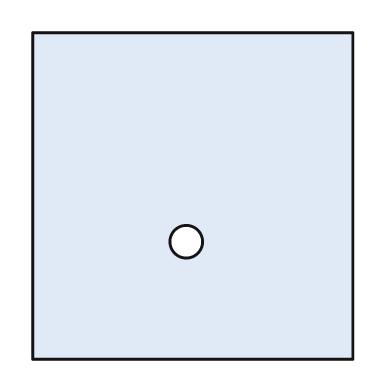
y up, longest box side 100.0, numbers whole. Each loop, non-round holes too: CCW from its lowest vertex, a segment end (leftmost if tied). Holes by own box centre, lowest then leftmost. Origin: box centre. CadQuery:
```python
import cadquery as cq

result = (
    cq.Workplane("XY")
    .moveTo(-49.0, -50.0)
    .lineTo(49.0, -50.0)
    .lineTo(49.0, 50.0)
    .lineTo(-49.0, 50.0)
    .close()
    .moveTo(-2.0, -14.0)
    .circle(5.0)
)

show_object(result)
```